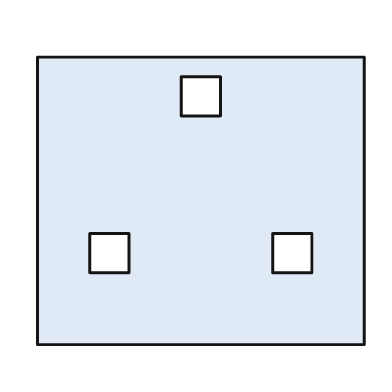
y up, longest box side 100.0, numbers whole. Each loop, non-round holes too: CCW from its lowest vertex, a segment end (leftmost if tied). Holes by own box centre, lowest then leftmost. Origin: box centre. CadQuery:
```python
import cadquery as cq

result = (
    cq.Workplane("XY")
    .moveTo(-50.0, -44.0)
    .lineTo(50.0, -44.0)
    .lineTo(50.0, 44.0)
    .lineTo(-50.0, 44.0)
    .close()
    .moveTo(-34.0, -22.0)
    .lineTo(-22.0, -22.0)
    .lineTo(-22.0, -10.0)
    .lineTo(-34.0, -10.0)
    .close()
    .moveTo(22.0, -22.0)
    .lineTo(34.0, -22.0)
    .lineTo(34.0, -10.0)
    .lineTo(22.0, -10.0)
    .close()
    .moveTo(-6.0, 26.0)
    .lineTo(6.0, 26.0)
    .lineTo(6.0, 38.0)
    .lineTo(-6.0, 38.0)
    .close()
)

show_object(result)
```